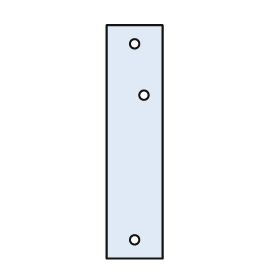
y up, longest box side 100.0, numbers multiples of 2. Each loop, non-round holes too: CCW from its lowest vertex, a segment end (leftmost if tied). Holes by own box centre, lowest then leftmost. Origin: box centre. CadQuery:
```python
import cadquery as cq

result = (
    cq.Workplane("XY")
    .moveTo(-12.0, -50.0)
    .lineTo(12.0, -50.0)
    .lineTo(12.0, 50.0)
    .lineTo(-12.0, 50.0)
    .close()
    .moveTo(0.0, -42.0)
    .circle(2.0)
    .moveTo(4.0, 20.0)
    .circle(2.0)
    .moveTo(0.0, 42.0)
    .circle(2.0)
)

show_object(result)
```